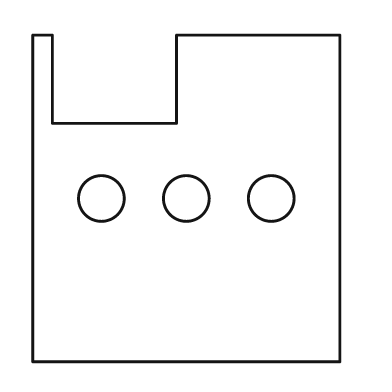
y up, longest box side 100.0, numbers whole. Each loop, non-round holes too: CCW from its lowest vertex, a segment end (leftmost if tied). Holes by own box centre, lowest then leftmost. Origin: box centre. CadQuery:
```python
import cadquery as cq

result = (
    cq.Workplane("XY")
    .moveTo(-47.0, -50.0)
    .lineTo(47.0, -50.0)
    .lineTo(47.0, 50.0)
    .lineTo(-3.0, 50.0)
    .lineTo(-3.0, 23.0)
    .lineTo(-41.0, 23.0)
    .lineTo(-41.0, 50.0)
    .lineTo(-47.0, 50.0)
    .close()
    .moveTo(-26.0, 0.0)
    .circle(7.0)
    .moveTo(0.0, 0.0)
    .circle(7.0)
    .moveTo(26.0, 0.0)
    .circle(7.0)
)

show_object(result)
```